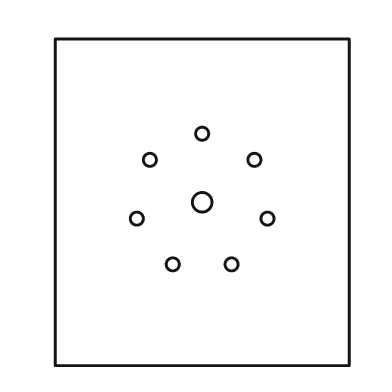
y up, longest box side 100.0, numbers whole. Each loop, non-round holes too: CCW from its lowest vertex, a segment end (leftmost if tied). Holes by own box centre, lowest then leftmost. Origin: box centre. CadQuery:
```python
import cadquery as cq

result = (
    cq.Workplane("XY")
    .moveTo(-45.0, -50.0)
    .lineTo(45.0, -50.0)
    .lineTo(45.0, 50.0)
    .lineTo(-45.0, 50.0)
    .close()
    .moveTo(-9.0, -19.0)
    .circle(2.0)
    .moveTo(9.0, -19.0)
    .circle(2.0)
    .moveTo(-20.0, -5.0)
    .circle(2.0)
    .moveTo(20.0, -5.0)
    .circle(2.0)
    .moveTo(0.0, 0.0)
    .circle(3.0)
    .moveTo(-16.0, 13.0)
    .circle(2.0)
    .moveTo(16.0, 13.0)
    .circle(2.0)
    .moveTo(0.0, 21.0)
    .circle(2.0)
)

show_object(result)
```